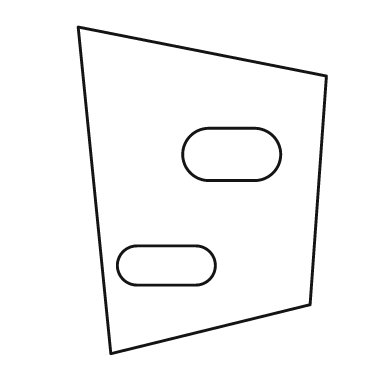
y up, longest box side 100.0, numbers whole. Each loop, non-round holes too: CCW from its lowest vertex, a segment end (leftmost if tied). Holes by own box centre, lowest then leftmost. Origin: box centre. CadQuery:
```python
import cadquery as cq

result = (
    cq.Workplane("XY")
    .moveTo(-28.0, -50.0)
    .lineTo(33.0, -35.0)
    .lineTo(38.0, 35.0)
    .lineTo(-38.0, 50.0)
    .close()
    .moveTo(-20.0, -29.0)
    .lineTo(-2.0, -29.0)
    .threePointArc((4.0, -23.0), (-2.0, -17.0))
    .lineTo(-20.0, -17.0)
    .threePointArc((-26.0, -23.0), (-20.0, -29.0))
    .close()
    .moveTo(2.0, 3.0)
    .lineTo(16.0, 3.0)
    .threePointArc((24.0, 11.0), (16.0, 19.0))
    .lineTo(2.0, 19.0)
    .threePointArc((-6.0, 11.0), (2.0, 3.0))
    .close()
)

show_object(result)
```